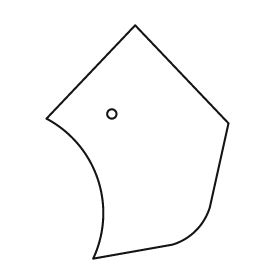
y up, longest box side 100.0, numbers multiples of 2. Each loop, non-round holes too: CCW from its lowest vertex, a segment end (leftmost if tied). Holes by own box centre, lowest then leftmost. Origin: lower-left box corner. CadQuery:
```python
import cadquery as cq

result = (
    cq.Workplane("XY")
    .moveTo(20.0, 0.0)
    .lineTo(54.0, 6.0)
    .threePointArc((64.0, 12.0), (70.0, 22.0))
    .lineTo(78.0, 58.0)
    .lineTo(38.0, 100.0)
    .lineTo(0.0, 60.0)
    .threePointArc((22.0, 34.0), (20.0, 0.0))
    .close()
    .moveTo(28.0, 62.0)
    .circle(2.0)
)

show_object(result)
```